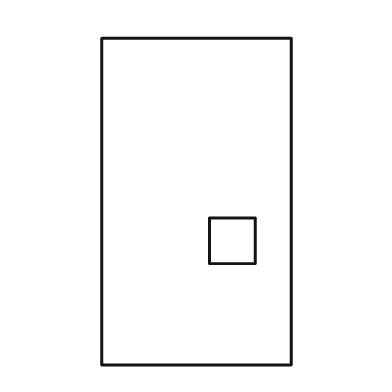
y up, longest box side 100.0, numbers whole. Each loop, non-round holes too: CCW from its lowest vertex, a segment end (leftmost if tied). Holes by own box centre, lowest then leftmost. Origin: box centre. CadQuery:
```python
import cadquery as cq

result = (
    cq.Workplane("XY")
    .moveTo(-29.0, -50.0)
    .lineTo(29.0, -50.0)
    .lineTo(29.0, 50.0)
    .lineTo(-29.0, 50.0)
    .close()
    .moveTo(4.0, -19.0)
    .lineTo(18.0, -19.0)
    .lineTo(18.0, -5.0)
    .lineTo(4.0, -5.0)
    .close()
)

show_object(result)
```